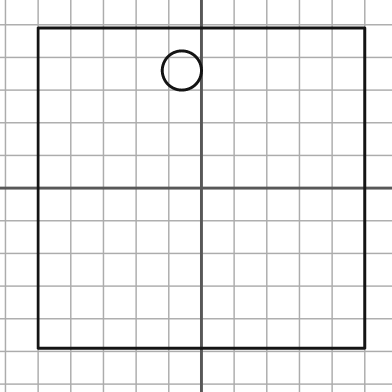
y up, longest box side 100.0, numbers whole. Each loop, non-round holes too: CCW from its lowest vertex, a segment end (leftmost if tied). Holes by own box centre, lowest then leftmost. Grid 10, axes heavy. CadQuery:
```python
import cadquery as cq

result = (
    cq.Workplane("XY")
    .moveTo(-50.0, -49.0)
    .lineTo(50.0, -49.0)
    .lineTo(50.0, 49.0)
    .lineTo(-50.0, 49.0)
    .close()
    .moveTo(-6.0, 36.0)
    .circle(6.0)
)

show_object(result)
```